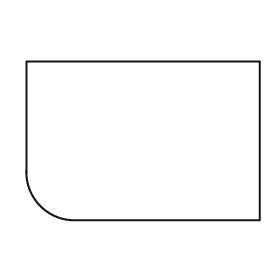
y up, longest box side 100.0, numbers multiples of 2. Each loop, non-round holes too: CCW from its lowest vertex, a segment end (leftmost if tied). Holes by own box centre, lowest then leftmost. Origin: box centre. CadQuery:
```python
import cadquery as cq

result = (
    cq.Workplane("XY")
    .moveTo(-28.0, -34.0)
    .lineTo(50.0, -34.0)
    .lineTo(50.0, 34.0)
    .lineTo(-50.0, 34.0)
    .lineTo(-50.0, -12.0)
    .threePointArc((-44.0, -28.0), (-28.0, -34.0))
    .close()
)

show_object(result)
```